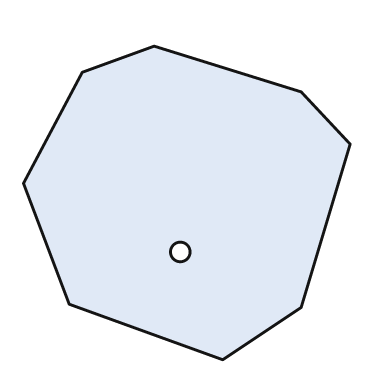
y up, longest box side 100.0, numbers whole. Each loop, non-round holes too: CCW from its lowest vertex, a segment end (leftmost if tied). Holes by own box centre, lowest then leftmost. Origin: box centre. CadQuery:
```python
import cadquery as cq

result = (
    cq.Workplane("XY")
    .moveTo(11.0, -48.0)
    .lineTo(35.0, -32.0)
    .lineTo(50.0, 18.0)
    .lineTo(35.0, 34.0)
    .lineTo(-10.0, 48.0)
    .lineTo(-32.0, 40.0)
    .lineTo(-50.0, 6.0)
    .lineTo(-36.0, -31.0)
    .close()
    .moveTo(-2.0, -15.0)
    .circle(3.0)
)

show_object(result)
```